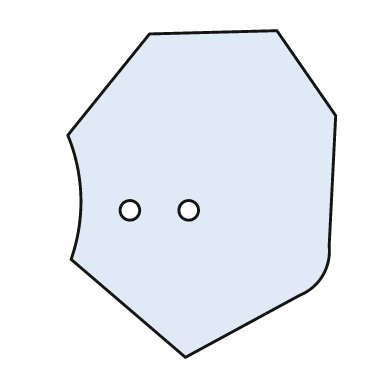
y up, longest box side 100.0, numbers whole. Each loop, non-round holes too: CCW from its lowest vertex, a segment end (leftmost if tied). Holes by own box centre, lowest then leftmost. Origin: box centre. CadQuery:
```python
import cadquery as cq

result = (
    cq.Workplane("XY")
    .moveTo(-5.0, -50.0)
    .lineTo(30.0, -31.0)
    .threePointArc((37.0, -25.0), (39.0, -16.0))
    .lineTo(41.0, 24.0)
    .lineTo(23.0, 50.0)
    .lineTo(-16.0, 49.0)
    .lineTo(-41.0, 18.0)
    .threePointArc((-37.0, -1.0), (-40.0, -20.0))
    .close()
    .moveTo(-22.0, -5.0)
    .circle(3.0)
    .moveTo(-4.0, -5.0)
    .circle(3.0)
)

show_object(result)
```